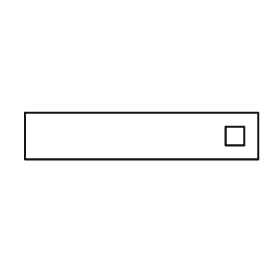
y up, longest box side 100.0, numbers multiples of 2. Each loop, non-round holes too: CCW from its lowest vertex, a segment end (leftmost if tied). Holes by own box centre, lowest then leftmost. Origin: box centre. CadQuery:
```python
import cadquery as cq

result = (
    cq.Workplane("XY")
    .moveTo(-50.0, -10.0)
    .lineTo(50.0, -10.0)
    .lineTo(50.0, 10.0)
    .lineTo(-50.0, 10.0)
    .close()
    .moveTo(36.0, -4.0)
    .lineTo(44.0, -4.0)
    .lineTo(44.0, 4.0)
    .lineTo(36.0, 4.0)
    .close()
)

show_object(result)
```